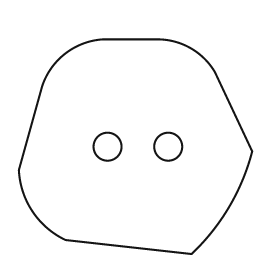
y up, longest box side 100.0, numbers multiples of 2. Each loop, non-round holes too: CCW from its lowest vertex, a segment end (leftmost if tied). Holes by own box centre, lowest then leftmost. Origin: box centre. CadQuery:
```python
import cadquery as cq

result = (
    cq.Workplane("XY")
    .moveTo(24.0, -46.0)
    .threePointArc((40.0, -26.0), (50.0, -2.0))
    .lineTo(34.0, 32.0)
    .threePointArc((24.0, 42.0), (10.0, 46.0))
    .lineTo(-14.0, 46.0)
    .threePointArc((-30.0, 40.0), (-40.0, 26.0))
    .lineTo(-50.0, -10.0)
    .threePointArc((-44.0, -28.0), (-30.0, -40.0))
    .close()
    .moveTo(-12.0, 0.0)
    .circle(6.0)
    .moveTo(14.0, 0.0)
    .circle(6.0)
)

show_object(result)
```